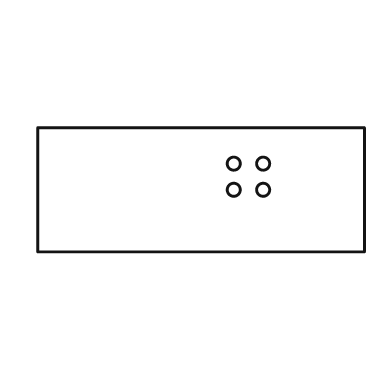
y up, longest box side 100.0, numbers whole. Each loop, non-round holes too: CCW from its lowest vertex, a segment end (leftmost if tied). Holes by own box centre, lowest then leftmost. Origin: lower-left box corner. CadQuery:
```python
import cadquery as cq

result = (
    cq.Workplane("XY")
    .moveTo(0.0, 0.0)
    .lineTo(100.0, 0.0)
    .lineTo(100.0, 38.0)
    .lineTo(0.0, 38.0)
    .close()
    .moveTo(60.0, 19.0)
    .circle(2.0)
    .moveTo(69.0, 19.0)
    .circle(2.0)
    .moveTo(60.0, 27.0)
    .circle(2.0)
    .moveTo(69.0, 27.0)
    .circle(2.0)
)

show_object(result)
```